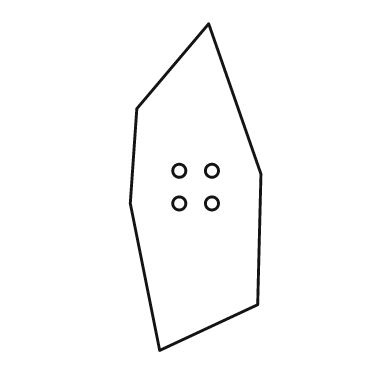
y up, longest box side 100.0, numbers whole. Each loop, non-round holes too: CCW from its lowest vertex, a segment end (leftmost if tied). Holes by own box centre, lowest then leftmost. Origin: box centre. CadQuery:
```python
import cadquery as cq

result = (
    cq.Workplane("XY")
    .moveTo(-11.0, -50.0)
    .lineTo(19.0, -36.0)
    .lineTo(20.0, 4.0)
    .lineTo(4.0, 50.0)
    .lineTo(-18.0, 24.0)
    .lineTo(-20.0, -5.0)
    .close()
    .moveTo(-5.0, -5.0)
    .circle(2.0)
    .moveTo(5.0, -5.0)
    .circle(2.0)
    .moveTo(-5.0, 5.0)
    .circle(2.0)
    .moveTo(5.0, 5.0)
    .circle(2.0)
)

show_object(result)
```